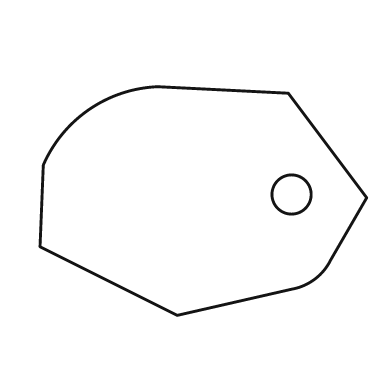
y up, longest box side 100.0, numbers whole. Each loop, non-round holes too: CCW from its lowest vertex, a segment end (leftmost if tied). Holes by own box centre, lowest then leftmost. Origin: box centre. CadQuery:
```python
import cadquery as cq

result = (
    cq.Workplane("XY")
    .moveTo(-8.0, -35.0)
    .lineTo(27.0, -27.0)
    .threePointArc((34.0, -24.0), (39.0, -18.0))
    .lineTo(50.0, 1.0)
    .lineTo(26.0, 33.0)
    .lineTo(-14.0, 35.0)
    .threePointArc((-35.0, 28.0), (-49.0, 11.0))
    .lineTo(-50.0, -14.0)
    .close()
    .moveTo(27.0, 2.0)
    .circle(6.0)
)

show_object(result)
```